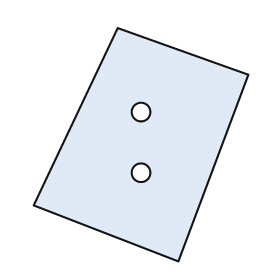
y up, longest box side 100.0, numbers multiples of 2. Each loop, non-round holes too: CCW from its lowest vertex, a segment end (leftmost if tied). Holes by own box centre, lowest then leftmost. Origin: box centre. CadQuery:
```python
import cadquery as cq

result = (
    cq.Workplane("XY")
    .moveTo(16.0, -50.0)
    .lineTo(46.0, 30.0)
    .lineTo(-10.0, 50.0)
    .lineTo(-46.0, -26.0)
    .close()
    .moveTo(0.0, -12.0)
    .circle(4.0)
    .moveTo(0.0, 14.0)
    .circle(4.0)
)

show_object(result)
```